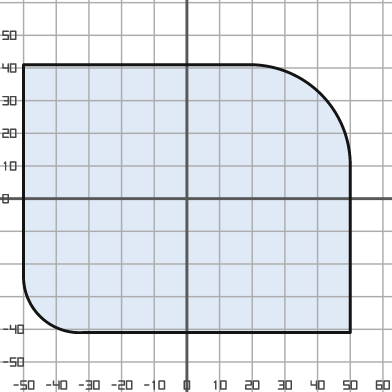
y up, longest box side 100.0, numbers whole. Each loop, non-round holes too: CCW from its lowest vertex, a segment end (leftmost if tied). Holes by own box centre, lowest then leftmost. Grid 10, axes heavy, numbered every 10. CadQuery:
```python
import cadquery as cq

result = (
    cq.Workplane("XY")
    .moveTo(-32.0, -41.0)
    .lineTo(50.0, -41.0)
    .lineTo(50.0, 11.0)
    .threePointArc((41.0, 32.0), (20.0, 41.0))
    .lineTo(-50.0, 41.0)
    .lineTo(-50.0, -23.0)
    .threePointArc((-45.0, -36.0), (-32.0, -41.0))
    .close()
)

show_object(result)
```